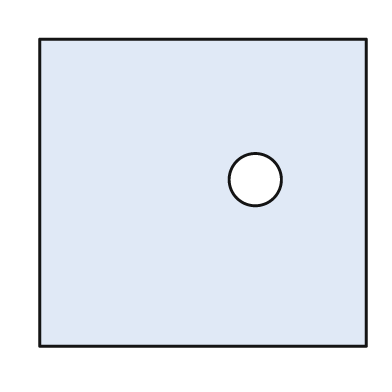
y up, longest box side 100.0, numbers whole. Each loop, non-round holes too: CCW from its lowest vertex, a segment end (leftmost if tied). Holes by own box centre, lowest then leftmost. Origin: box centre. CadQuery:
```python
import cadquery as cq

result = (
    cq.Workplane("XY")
    .moveTo(-50.0, -47.0)
    .lineTo(50.0, -47.0)
    .lineTo(50.0, 47.0)
    .lineTo(-50.0, 47.0)
    .close()
    .moveTo(16.0, 4.0)
    .circle(8.0)
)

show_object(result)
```